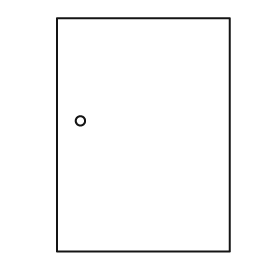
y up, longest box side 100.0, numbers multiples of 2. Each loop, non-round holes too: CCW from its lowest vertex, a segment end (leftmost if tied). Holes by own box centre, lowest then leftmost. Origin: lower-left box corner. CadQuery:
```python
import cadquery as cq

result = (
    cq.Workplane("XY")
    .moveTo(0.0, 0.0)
    .lineTo(74.0, 0.0)
    .lineTo(74.0, 100.0)
    .lineTo(0.0, 100.0)
    .close()
    .moveTo(10.0, 56.0)
    .circle(2.0)
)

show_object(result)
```